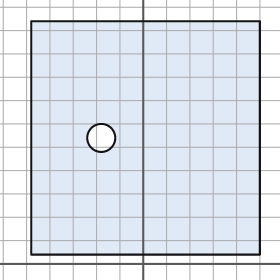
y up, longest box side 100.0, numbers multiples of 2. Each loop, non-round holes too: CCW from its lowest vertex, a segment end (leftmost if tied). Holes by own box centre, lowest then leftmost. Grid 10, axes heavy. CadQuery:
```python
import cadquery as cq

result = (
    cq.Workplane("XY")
    .moveTo(-48.0, 4.0)
    .lineTo(50.0, 4.0)
    .lineTo(50.0, 104.0)
    .lineTo(-48.0, 104.0)
    .close()
    .moveTo(-18.0, 54.0)
    .circle(6.0)
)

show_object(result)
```